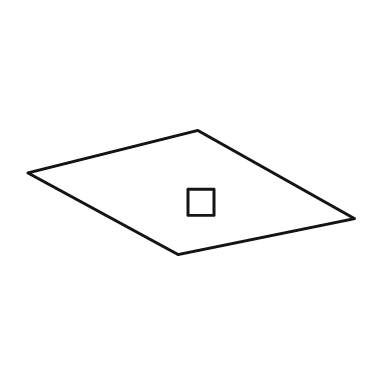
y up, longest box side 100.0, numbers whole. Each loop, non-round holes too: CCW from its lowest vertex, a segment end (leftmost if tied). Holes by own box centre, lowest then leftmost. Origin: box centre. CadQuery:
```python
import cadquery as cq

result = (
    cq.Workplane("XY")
    .moveTo(-4.0, -19.0)
    .lineTo(50.0, -8.0)
    .lineTo(2.0, 19.0)
    .lineTo(-50.0, 6.0)
    .close()
    .moveTo(-1.0, -7.0)
    .lineTo(7.0, -7.0)
    .lineTo(7.0, 1.0)
    .lineTo(-1.0, 1.0)
    .close()
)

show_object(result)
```